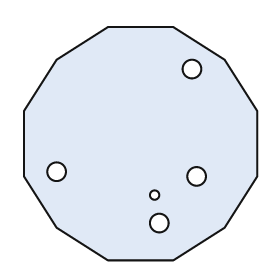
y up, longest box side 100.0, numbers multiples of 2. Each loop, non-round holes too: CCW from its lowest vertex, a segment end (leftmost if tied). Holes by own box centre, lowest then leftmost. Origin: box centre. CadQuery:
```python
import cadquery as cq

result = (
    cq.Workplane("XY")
    .moveTo(-14.0, -50.0)
    .lineTo(14.0, -50.0)
    .lineTo(36.0, -36.0)
    .lineTo(50.0, -14.0)
    .lineTo(50.0, 14.0)
    .lineTo(36.0, 36.0)
    .lineTo(14.0, 50.0)
    .lineTo(-14.0, 50.0)
    .lineTo(-36.0, 36.0)
    .lineTo(-50.0, 14.0)
    .lineTo(-50.0, -14.0)
    .lineTo(-36.0, -36.0)
    .close()
    .moveTo(8.0, -34.0)
    .circle(4.0)
    .moveTo(6.0, -22.0)
    .circle(2.0)
    .moveTo(24.0, -14.0)
    .circle(4.0)
    .moveTo(-36.0, -12.0)
    .circle(4.0)
    .moveTo(22.0, 32.0)
    .circle(4.0)
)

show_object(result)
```